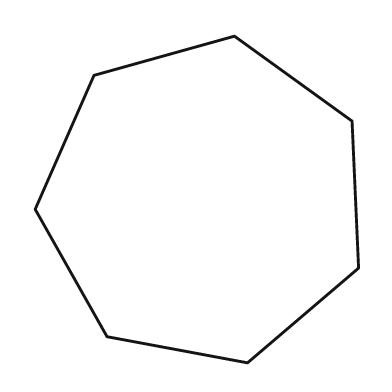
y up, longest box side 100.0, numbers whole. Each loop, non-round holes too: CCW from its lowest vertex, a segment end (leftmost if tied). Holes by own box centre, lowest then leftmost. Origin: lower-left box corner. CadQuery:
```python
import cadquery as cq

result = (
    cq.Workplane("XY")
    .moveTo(65.0, 0.0)
    .lineTo(99.0, 29.0)
    .lineTo(97.0, 74.0)
    .lineTo(61.0, 100.0)
    .lineTo(18.0, 88.0)
    .lineTo(0.0, 47.0)
    .lineTo(22.0, 8.0)
    .close()
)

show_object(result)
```